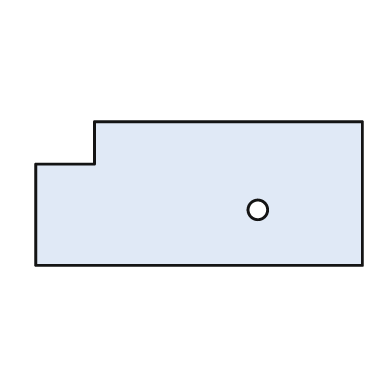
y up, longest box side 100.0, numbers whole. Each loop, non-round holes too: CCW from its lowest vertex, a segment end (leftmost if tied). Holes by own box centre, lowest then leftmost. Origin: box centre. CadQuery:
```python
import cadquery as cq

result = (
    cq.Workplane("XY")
    .moveTo(-50.0, -22.0)
    .lineTo(50.0, -22.0)
    .lineTo(50.0, 22.0)
    .lineTo(-32.0, 22.0)
    .lineTo(-32.0, 9.0)
    .lineTo(-50.0, 9.0)
    .close()
    .moveTo(18.0, -5.0)
    .circle(3.0)
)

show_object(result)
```